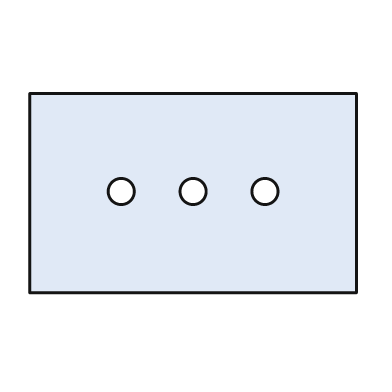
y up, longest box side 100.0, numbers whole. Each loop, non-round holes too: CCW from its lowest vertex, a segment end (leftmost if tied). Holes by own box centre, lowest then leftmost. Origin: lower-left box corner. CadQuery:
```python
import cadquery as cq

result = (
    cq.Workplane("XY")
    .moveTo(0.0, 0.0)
    .lineTo(100.0, 0.0)
    .lineTo(100.0, 61.0)
    .lineTo(0.0, 61.0)
    .close()
    .moveTo(28.0, 31.0)
    .circle(4.0)
    .moveTo(50.0, 31.0)
    .circle(4.0)
    .moveTo(72.0, 31.0)
    .circle(4.0)
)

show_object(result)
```